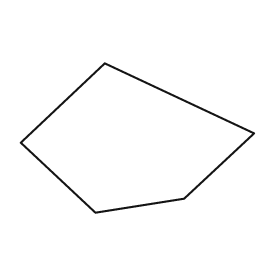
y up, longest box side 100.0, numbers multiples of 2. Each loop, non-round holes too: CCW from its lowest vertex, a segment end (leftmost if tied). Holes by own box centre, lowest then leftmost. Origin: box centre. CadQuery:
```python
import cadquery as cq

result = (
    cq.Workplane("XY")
    .moveTo(-18.0, -32.0)
    .lineTo(20.0, -26.0)
    .lineTo(50.0, 2.0)
    .lineTo(-14.0, 32.0)
    .lineTo(-50.0, -2.0)
    .close()
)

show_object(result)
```